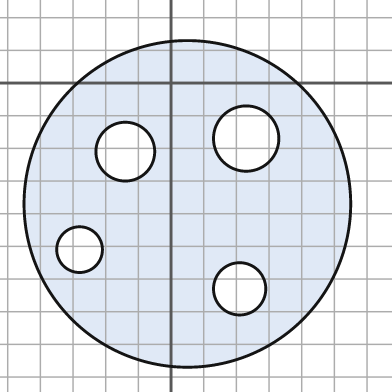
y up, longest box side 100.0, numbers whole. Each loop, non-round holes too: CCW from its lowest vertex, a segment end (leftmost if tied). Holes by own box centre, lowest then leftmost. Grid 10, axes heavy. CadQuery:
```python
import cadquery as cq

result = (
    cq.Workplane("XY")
    .moveTo(5.0, -37.0)
    .circle(50.0)
    .moveTo(21.0, -63.0)
    .circle(8.0)
    .moveTo(-28.0, -51.0)
    .circle(7.0)
    .moveTo(-14.0, -21.0)
    .circle(9.0)
    .moveTo(23.0, -17.0)
    .circle(10.0)
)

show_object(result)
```